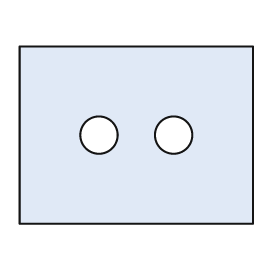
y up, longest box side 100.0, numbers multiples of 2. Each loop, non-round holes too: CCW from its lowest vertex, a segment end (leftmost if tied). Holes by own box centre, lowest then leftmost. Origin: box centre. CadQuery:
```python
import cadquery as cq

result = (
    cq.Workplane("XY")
    .moveTo(-50.0, -38.0)
    .lineTo(50.0, -38.0)
    .lineTo(50.0, 38.0)
    .lineTo(-50.0, 38.0)
    .close()
    .moveTo(-16.0, 0.0)
    .circle(8.0)
    .moveTo(16.0, 0.0)
    .circle(8.0)
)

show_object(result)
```